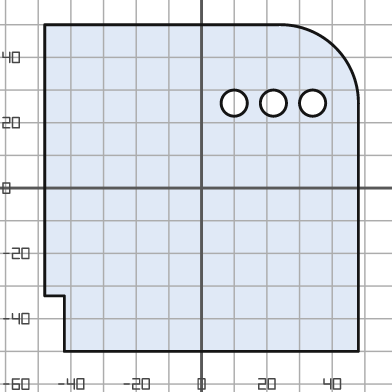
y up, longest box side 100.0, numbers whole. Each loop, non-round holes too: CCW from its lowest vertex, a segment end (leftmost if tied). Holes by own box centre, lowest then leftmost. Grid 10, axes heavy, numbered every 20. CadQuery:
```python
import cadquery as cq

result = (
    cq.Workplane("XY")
    .moveTo(-42.0, -50.0)
    .lineTo(48.0, -50.0)
    .lineTo(48.0, 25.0)
    .threePointArc((41.0, 43.0), (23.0, 50.0))
    .lineTo(-48.0, 50.0)
    .lineTo(-48.0, -33.0)
    .lineTo(-42.0, -33.0)
    .close()
    .moveTo(10.0, 26.0)
    .circle(4.0)
    .moveTo(22.0, 26.0)
    .circle(4.0)
    .moveTo(34.0, 26.0)
    .circle(4.0)
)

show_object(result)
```